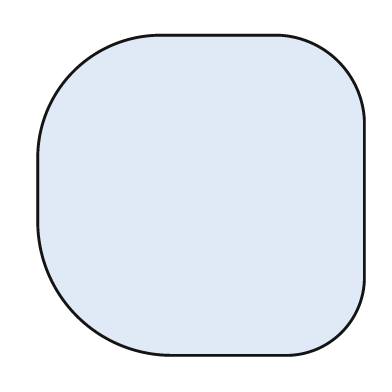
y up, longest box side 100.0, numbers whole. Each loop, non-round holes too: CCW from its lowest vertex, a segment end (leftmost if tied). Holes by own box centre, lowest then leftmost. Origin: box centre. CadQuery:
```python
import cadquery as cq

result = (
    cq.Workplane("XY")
    .moveTo(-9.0, -49.0)
    .lineTo(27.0, -49.0)
    .threePointArc((43.0, -42.0), (50.0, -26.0))
    .lineTo(50.0, 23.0)
    .threePointArc((42.0, 41.0), (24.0, 49.0))
    .lineTo(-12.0, 49.0)
    .threePointArc((-39.0, 38.0), (-50.0, 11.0))
    .lineTo(-50.0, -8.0)
    .threePointArc((-38.0, -37.0), (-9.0, -49.0))
    .close()
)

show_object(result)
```